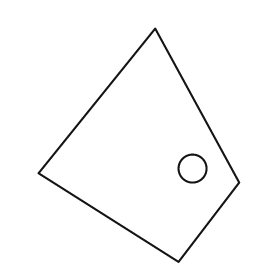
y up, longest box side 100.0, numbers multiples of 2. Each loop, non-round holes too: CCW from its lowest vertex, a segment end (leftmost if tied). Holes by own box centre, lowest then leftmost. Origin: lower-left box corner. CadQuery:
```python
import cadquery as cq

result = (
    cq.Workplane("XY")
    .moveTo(60.0, 0.0)
    .lineTo(86.0, 34.0)
    .lineTo(50.0, 100.0)
    .lineTo(0.0, 38.0)
    .close()
    .moveTo(66.0, 40.0)
    .circle(6.0)
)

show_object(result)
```